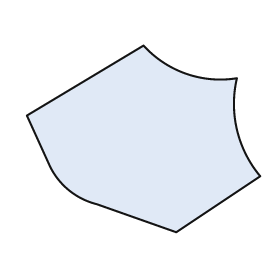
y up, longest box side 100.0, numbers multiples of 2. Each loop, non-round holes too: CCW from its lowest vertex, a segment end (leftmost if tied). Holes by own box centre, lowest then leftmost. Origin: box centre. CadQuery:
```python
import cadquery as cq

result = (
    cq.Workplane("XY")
    .moveTo(14.0, -40.0)
    .lineTo(50.0, -16.0)
    .threePointArc((40.0, 4.0), (40.0, 26.0))
    .threePointArc((18.0, 28.0), (0.0, 40.0))
    .lineTo(-50.0, 10.0)
    .lineTo(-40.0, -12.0)
    .threePointArc((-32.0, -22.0), (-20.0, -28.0))
    .close()
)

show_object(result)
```